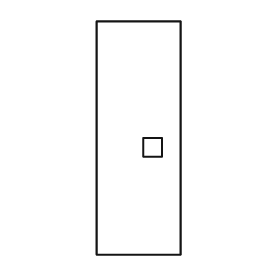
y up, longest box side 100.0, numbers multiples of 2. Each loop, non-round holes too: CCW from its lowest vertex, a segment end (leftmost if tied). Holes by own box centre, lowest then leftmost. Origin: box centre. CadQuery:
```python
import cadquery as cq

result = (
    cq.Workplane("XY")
    .moveTo(-18.0, -50.0)
    .lineTo(18.0, -50.0)
    .lineTo(18.0, 50.0)
    .lineTo(-18.0, 50.0)
    .close()
    .moveTo(2.0, -8.0)
    .lineTo(10.0, -8.0)
    .lineTo(10.0, 0.0)
    .lineTo(2.0, 0.0)
    .close()
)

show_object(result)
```